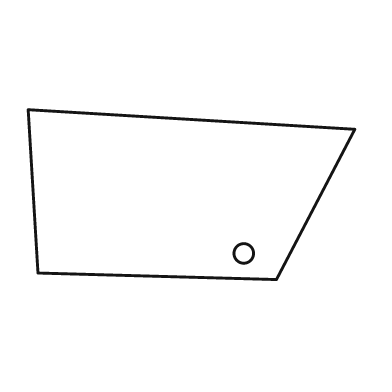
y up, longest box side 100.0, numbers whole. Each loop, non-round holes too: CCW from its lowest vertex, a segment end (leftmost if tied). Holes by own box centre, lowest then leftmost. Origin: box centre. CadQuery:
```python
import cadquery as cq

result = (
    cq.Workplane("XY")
    .moveTo(26.0, -26.0)
    .lineTo(50.0, 20.0)
    .lineTo(-50.0, 26.0)
    .lineTo(-47.0, -24.0)
    .close()
    .moveTo(16.0, -18.0)
    .circle(3.0)
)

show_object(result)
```